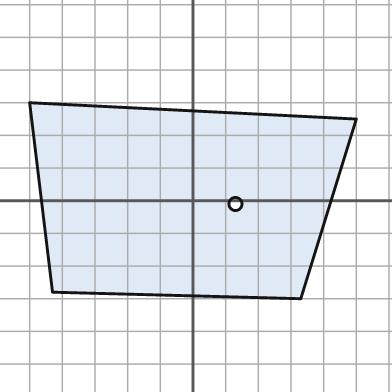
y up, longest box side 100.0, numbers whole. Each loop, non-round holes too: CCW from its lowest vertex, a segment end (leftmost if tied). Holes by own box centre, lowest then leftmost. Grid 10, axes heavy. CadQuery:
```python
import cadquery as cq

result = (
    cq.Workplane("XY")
    .moveTo(33.0, -30.0)
    .lineTo(50.0, 25.0)
    .lineTo(-50.0, 30.0)
    .lineTo(-43.0, -28.0)
    .close()
    .moveTo(13.0, -1.0)
    .circle(2.0)
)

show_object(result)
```